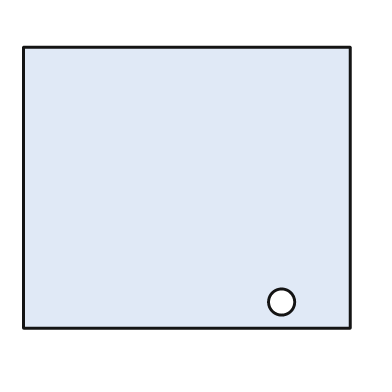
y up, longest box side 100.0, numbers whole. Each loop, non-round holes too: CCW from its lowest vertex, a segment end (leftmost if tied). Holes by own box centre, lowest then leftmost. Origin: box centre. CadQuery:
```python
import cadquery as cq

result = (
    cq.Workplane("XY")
    .moveTo(-50.0, -43.0)
    .lineTo(50.0, -43.0)
    .lineTo(50.0, 43.0)
    .lineTo(-50.0, 43.0)
    .close()
    .moveTo(29.0, -35.0)
    .circle(4.0)
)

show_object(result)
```